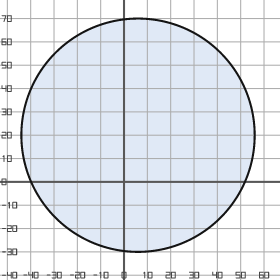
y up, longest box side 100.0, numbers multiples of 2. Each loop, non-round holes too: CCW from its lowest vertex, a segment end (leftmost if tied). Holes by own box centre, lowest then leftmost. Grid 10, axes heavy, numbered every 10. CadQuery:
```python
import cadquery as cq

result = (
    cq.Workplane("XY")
    .moveTo(6.0, 20.0)
    .circle(50.0)
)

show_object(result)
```